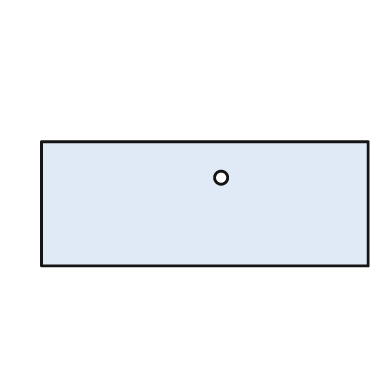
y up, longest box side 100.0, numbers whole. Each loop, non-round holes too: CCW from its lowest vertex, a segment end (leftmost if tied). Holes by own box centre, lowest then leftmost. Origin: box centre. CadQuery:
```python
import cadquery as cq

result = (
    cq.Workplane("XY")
    .moveTo(-50.0, -19.0)
    .lineTo(50.0, -19.0)
    .lineTo(50.0, 19.0)
    .lineTo(-50.0, 19.0)
    .close()
    .moveTo(5.0, 8.0)
    .circle(2.0)
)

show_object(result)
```